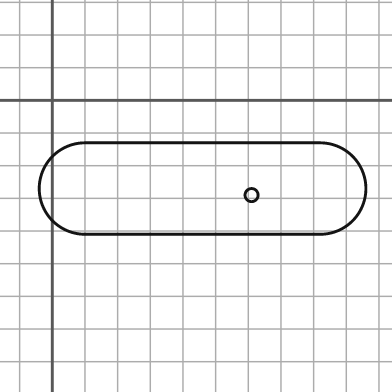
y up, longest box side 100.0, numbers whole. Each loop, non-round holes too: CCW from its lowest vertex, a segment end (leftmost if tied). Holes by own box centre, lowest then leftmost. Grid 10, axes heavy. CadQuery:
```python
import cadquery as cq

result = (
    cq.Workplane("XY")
    .moveTo(10.0, -41.0)
    .lineTo(82.0, -41.0)
    .threePointArc((96.0, -27.0), (82.0, -13.0))
    .lineTo(10.0, -13.0)
    .threePointArc((-4.0, -27.0), (10.0, -41.0))
    .close()
    .moveTo(61.0, -29.0)
    .circle(2.0)
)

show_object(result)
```